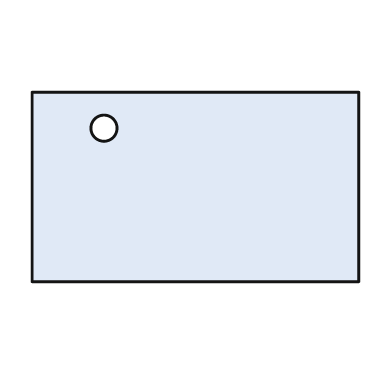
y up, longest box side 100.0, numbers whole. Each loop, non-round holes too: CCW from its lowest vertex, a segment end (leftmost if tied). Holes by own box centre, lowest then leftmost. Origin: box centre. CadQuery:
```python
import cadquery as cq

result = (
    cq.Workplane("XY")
    .moveTo(-50.0, -29.0)
    .lineTo(50.0, -29.0)
    .lineTo(50.0, 29.0)
    .lineTo(-50.0, 29.0)
    .close()
    .moveTo(-28.0, 18.0)
    .circle(4.0)
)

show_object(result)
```